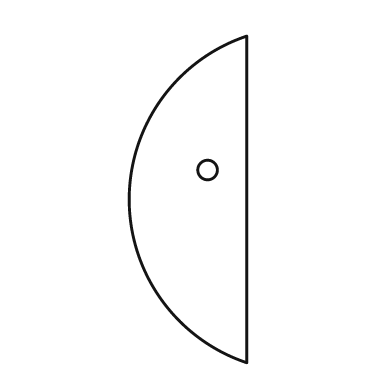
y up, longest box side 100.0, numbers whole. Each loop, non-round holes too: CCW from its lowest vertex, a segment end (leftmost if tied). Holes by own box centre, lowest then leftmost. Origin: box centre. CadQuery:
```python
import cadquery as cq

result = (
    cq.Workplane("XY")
    .moveTo(18.0, -50.0)
    .lineTo(18.0, 50.0)
    .threePointArc((-18.0, 0.0), (18.0, -50.0))
    .close()
    .moveTo(6.0, 9.0)
    .circle(3.0)
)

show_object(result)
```